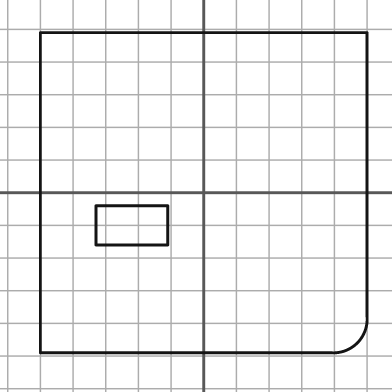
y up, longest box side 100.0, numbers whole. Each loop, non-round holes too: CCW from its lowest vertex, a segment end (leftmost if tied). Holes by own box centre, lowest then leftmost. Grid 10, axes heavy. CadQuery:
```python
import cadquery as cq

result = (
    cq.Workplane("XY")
    .moveTo(-50.0, -49.0)
    .lineTo(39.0, -49.0)
    .threePointArc((47.0, -46.0), (50.0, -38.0))
    .lineTo(50.0, 49.0)
    .lineTo(-50.0, 49.0)
    .close()
    .moveTo(-33.0, -16.0)
    .lineTo(-11.0, -16.0)
    .lineTo(-11.0, -4.0)
    .lineTo(-33.0, -4.0)
    .close()
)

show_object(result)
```